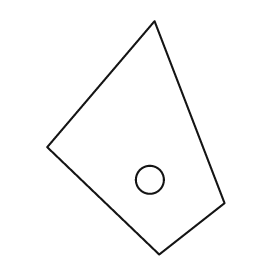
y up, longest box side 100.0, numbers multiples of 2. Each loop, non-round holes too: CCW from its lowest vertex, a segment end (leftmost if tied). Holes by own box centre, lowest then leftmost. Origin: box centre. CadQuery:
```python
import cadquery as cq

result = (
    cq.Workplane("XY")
    .moveTo(10.0, -50.0)
    .lineTo(38.0, -28.0)
    .lineTo(8.0, 50.0)
    .lineTo(-38.0, -4.0)
    .close()
    .moveTo(6.0, -18.0)
    .circle(6.0)
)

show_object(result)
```